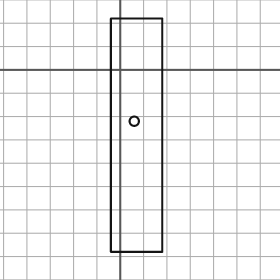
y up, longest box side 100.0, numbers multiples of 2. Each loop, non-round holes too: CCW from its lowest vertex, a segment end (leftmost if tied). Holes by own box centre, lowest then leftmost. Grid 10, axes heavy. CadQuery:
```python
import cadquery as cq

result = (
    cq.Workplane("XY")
    .moveTo(-4.0, -78.0)
    .lineTo(18.0, -78.0)
    .lineTo(18.0, 22.0)
    .lineTo(-4.0, 22.0)
    .close()
    .moveTo(6.0, -22.0)
    .circle(2.0)
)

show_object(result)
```